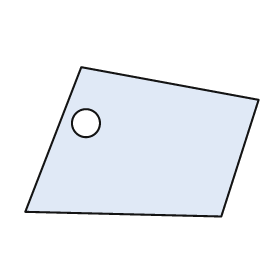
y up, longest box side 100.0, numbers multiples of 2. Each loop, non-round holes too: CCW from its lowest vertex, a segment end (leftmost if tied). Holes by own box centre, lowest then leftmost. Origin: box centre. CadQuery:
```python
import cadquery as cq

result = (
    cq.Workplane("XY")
    .moveTo(34.0, -32.0)
    .lineTo(50.0, 18.0)
    .lineTo(-26.0, 32.0)
    .lineTo(-50.0, -30.0)
    .close()
    .moveTo(-24.0, 8.0)
    .circle(6.0)
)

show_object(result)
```